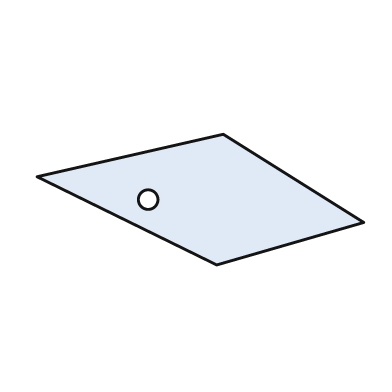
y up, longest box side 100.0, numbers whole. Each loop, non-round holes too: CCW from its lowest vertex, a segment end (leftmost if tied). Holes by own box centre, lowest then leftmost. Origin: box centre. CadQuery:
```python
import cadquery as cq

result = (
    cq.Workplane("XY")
    .moveTo(5.0, -20.0)
    .lineTo(50.0, -7.0)
    .lineTo(7.0, 20.0)
    .lineTo(-50.0, 7.0)
    .close()
    .moveTo(-16.0, 0.0)
    .circle(3.0)
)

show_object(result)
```